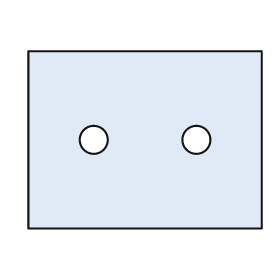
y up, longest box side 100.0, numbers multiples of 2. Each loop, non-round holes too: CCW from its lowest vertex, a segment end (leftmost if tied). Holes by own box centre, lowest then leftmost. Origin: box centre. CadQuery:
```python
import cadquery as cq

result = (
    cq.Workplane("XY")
    .moveTo(-50.0, -38.0)
    .lineTo(50.0, -38.0)
    .lineTo(50.0, 38.0)
    .lineTo(-50.0, 38.0)
    .close()
    .moveTo(-22.0, 0.0)
    .circle(6.0)
    .moveTo(22.0, 0.0)
    .circle(6.0)
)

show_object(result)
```